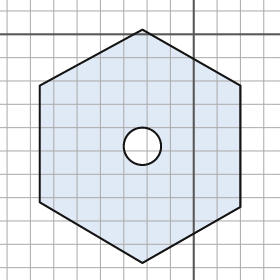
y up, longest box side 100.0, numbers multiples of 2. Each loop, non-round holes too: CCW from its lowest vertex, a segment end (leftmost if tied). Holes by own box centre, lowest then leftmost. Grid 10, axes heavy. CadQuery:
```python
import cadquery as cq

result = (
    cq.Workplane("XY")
    .moveTo(-22.0, -98.0)
    .lineTo(20.0, -74.0)
    .lineTo(20.0, -22.0)
    .lineTo(-22.0, 2.0)
    .lineTo(-66.0, -22.0)
    .lineTo(-66.0, -72.0)
    .close()
    .moveTo(-22.0, -48.0)
    .circle(8.0)
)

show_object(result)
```